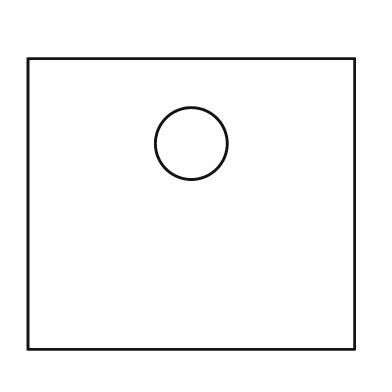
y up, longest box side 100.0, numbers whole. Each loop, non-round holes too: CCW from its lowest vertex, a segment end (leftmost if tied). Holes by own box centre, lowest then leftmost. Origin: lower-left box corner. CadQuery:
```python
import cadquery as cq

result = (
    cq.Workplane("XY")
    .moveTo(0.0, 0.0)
    .lineTo(100.0, 0.0)
    .lineTo(100.0, 89.0)
    .lineTo(0.0, 89.0)
    .close()
    .moveTo(50.0, 63.0)
    .circle(11.0)
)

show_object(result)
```